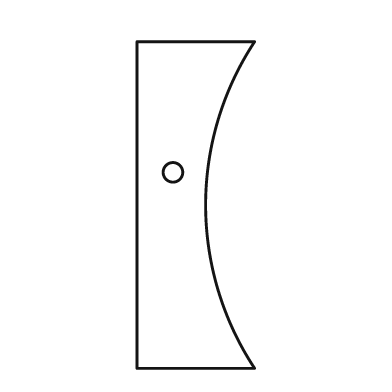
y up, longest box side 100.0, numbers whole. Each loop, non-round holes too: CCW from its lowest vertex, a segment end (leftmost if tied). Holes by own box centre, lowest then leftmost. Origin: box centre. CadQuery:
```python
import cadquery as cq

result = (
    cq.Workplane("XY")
    .moveTo(-18.0, -50.0)
    .lineTo(18.0, -50.0)
    .threePointArc((3.0, 0.0), (18.0, 50.0))
    .lineTo(-18.0, 50.0)
    .close()
    .moveTo(-7.0, 10.0)
    .circle(3.0)
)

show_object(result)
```